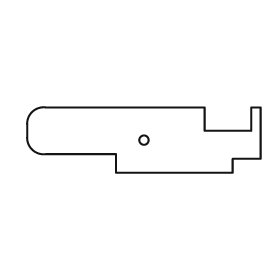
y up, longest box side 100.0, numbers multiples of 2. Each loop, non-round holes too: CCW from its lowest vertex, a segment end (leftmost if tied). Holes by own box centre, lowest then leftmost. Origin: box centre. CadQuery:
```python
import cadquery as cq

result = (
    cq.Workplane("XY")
    .moveTo(-12.0, -14.0)
    .lineTo(38.0, -14.0)
    .lineTo(38.0, -8.0)
    .lineTo(50.0, -8.0)
    .lineTo(50.0, 14.0)
    .lineTo(46.0, 14.0)
    .lineTo(46.0, 4.0)
    .lineTo(26.0, 4.0)
    .lineTo(26.0, 14.0)
    .lineTo(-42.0, 14.0)
    .threePointArc((-48.0, 12.0), (-50.0, 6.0))
    .lineTo(-50.0, 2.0)
    .threePointArc((-48.0, -4.0), (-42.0, -6.0))
    .lineTo(-12.0, -6.0)
    .close()
    .moveTo(0.0, 0.0)
    .circle(2.0)
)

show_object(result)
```